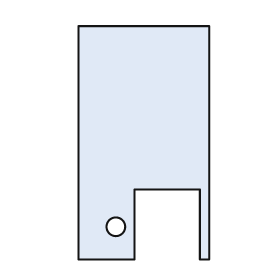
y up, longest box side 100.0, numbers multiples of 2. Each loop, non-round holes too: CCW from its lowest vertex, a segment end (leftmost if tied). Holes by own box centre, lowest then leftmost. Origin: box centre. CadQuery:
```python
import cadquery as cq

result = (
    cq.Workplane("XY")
    .moveTo(-28.0, -50.0)
    .lineTo(-4.0, -50.0)
    .lineTo(-4.0, -20.0)
    .lineTo(24.0, -20.0)
    .lineTo(24.0, -50.0)
    .lineTo(28.0, -50.0)
    .lineTo(28.0, 50.0)
    .lineTo(-28.0, 50.0)
    .close()
    .moveTo(-12.0, -36.0)
    .circle(4.0)
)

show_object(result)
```